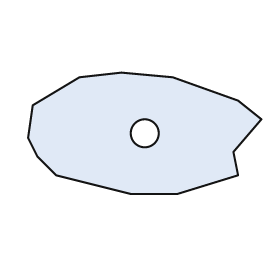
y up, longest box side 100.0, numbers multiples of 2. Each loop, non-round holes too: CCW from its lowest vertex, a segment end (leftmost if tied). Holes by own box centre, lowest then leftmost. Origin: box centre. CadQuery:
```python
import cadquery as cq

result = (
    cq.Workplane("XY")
    .moveTo(-6.0, -26.0)
    .lineTo(14.0, -26.0)
    .lineTo(40.0, -18.0)
    .lineTo(38.0, -8.0)
    .lineTo(50.0, 6.0)
    .lineTo(40.0, 14.0)
    .lineTo(12.0, 24.0)
    .lineTo(-10.0, 26.0)
    .lineTo(-28.0, 24.0)
    .lineTo(-48.0, 12.0)
    .lineTo(-50.0, -2.0)
    .lineTo(-46.0, -10.0)
    .lineTo(-38.0, -18.0)
    .close()
    .moveTo(0.0, 0.0)
    .circle(6.0)
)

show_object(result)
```